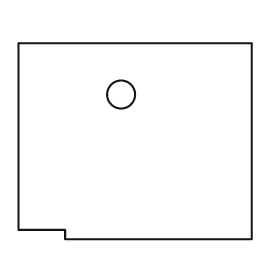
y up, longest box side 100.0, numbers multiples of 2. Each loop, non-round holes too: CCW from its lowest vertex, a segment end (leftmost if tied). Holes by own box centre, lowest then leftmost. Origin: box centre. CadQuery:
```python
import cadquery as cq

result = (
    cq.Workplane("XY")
    .moveTo(-30.0, -42.0)
    .lineTo(50.0, -42.0)
    .lineTo(50.0, 42.0)
    .lineTo(-50.0, 42.0)
    .lineTo(-50.0, -38.0)
    .lineTo(-30.0, -38.0)
    .close()
    .moveTo(-6.0, 20.0)
    .circle(6.0)
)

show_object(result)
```